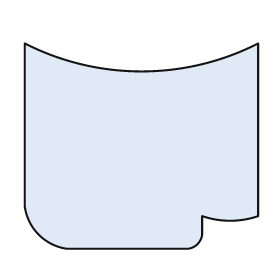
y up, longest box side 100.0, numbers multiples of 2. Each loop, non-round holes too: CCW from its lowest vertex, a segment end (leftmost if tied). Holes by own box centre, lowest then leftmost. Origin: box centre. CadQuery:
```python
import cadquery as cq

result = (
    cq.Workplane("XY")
    .moveTo(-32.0, -44.0)
    .lineTo(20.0, -44.0)
    .threePointArc((24.0, -42.0), (26.0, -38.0))
    .lineTo(26.0, -30.0)
    .threePointArc((38.0, -32.0), (50.0, -30.0))
    .lineTo(50.0, 44.0)
    .threePointArc((0.0, 32.0), (-50.0, 44.0))
    .lineTo(-50.0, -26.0)
    .threePointArc((-44.0, -38.0), (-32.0, -44.0))
    .close()
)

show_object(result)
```